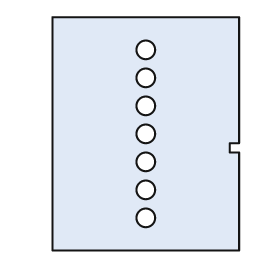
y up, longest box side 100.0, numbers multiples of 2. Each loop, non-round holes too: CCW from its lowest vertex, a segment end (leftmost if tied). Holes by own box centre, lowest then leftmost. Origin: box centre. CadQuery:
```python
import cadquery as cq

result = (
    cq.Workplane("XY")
    .moveTo(-40.0, -50.0)
    .lineTo(40.0, -50.0)
    .lineTo(40.0, -8.0)
    .lineTo(36.0, -8.0)
    .lineTo(36.0, -4.0)
    .lineTo(40.0, -4.0)
    .lineTo(40.0, 50.0)
    .lineTo(-40.0, 50.0)
    .close()
    .moveTo(0.0, -36.0)
    .circle(4.0)
    .moveTo(0.0, -24.0)
    .circle(4.0)
    .moveTo(0.0, -12.0)
    .circle(4.0)
    .moveTo(0.0, 0.0)
    .circle(4.0)
    .moveTo(0.0, 12.0)
    .circle(4.0)
    .moveTo(0.0, 24.0)
    .circle(4.0)
    .moveTo(0.0, 36.0)
    .circle(4.0)
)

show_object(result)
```